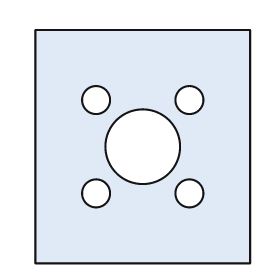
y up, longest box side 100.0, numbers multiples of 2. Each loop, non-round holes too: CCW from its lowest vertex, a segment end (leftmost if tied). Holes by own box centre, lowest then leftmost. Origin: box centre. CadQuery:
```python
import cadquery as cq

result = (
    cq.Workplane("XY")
    .moveTo(-46.0, -50.0)
    .lineTo(46.0, -50.0)
    .lineTo(46.0, 50.0)
    .lineTo(-46.0, 50.0)
    .close()
    .moveTo(-20.0, -20.0)
    .circle(6.0)
    .moveTo(20.0, -20.0)
    .circle(6.0)
    .moveTo(0.0, 0.0)
    .circle(16.0)
    .moveTo(-20.0, 20.0)
    .circle(6.0)
    .moveTo(20.0, 20.0)
    .circle(6.0)
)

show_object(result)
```